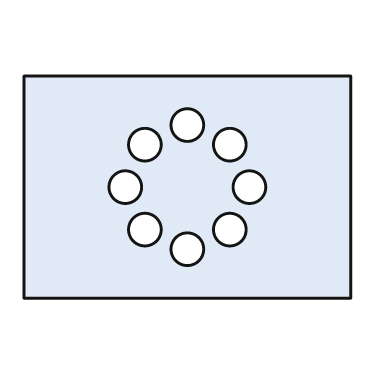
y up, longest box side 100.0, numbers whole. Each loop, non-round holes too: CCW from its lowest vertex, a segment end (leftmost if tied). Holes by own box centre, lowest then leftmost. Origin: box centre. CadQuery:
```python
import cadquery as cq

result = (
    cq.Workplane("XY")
    .moveTo(-50.0, -34.0)
    .lineTo(50.0, -34.0)
    .lineTo(50.0, 34.0)
    .lineTo(-50.0, 34.0)
    .close()
    .moveTo(0.0, -19.0)
    .circle(5.0)
    .moveTo(-13.0, -13.0)
    .circle(5.0)
    .moveTo(13.0, -13.0)
    .circle(5.0)
    .moveTo(-19.0, 0.0)
    .circle(5.0)
    .moveTo(19.0, 0.0)
    .circle(5.0)
    .moveTo(-13.0, 13.0)
    .circle(5.0)
    .moveTo(13.0, 13.0)
    .circle(5.0)
    .moveTo(0.0, 19.0)
    .circle(5.0)
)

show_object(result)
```